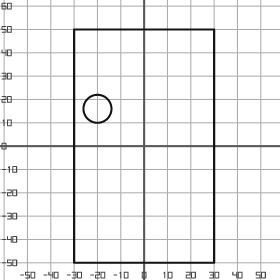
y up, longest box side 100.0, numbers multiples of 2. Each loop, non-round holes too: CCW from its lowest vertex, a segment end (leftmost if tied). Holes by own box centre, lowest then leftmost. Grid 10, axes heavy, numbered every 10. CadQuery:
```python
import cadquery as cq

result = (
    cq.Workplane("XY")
    .moveTo(-30.0, -50.0)
    .lineTo(30.0, -50.0)
    .lineTo(30.0, 50.0)
    .lineTo(-30.0, 50.0)
    .close()
    .moveTo(-20.0, 16.0)
    .circle(6.0)
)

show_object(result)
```